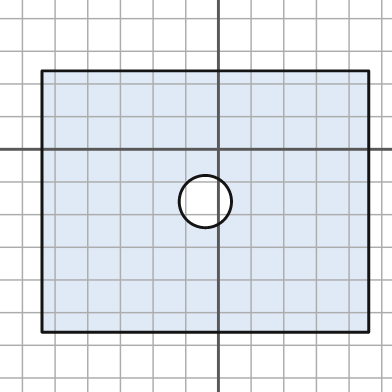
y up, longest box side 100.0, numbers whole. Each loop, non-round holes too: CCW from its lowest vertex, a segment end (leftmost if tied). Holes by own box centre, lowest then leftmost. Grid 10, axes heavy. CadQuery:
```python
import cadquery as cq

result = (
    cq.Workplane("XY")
    .moveTo(-54.0, -56.0)
    .lineTo(46.0, -56.0)
    .lineTo(46.0, 24.0)
    .lineTo(-54.0, 24.0)
    .close()
    .moveTo(-4.0, -16.0)
    .circle(8.0)
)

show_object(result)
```